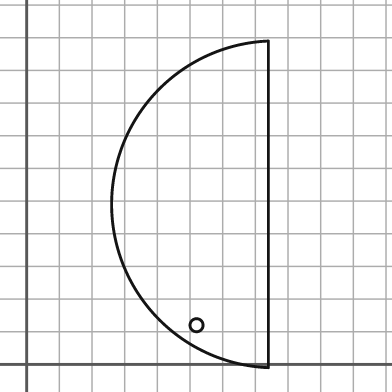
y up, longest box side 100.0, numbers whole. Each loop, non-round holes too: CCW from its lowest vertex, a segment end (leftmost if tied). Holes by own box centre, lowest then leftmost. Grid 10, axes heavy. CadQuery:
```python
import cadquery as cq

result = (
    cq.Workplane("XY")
    .moveTo(74.0, -1.0)
    .lineTo(74.0, 99.0)
    .threePointArc((26.0, 49.0), (74.0, -1.0))
    .close()
    .moveTo(52.0, 12.0)
    .circle(2.0)
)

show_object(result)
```